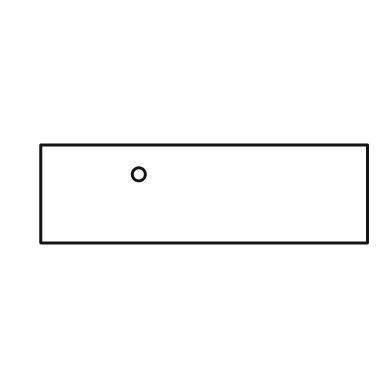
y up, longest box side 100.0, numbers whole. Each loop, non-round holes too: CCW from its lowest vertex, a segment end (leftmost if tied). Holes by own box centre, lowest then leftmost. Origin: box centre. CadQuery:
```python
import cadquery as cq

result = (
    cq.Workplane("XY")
    .moveTo(-50.0, -15.0)
    .lineTo(50.0, -15.0)
    .lineTo(50.0, 15.0)
    .lineTo(-50.0, 15.0)
    .close()
    .moveTo(-20.0, 6.0)
    .circle(2.0)
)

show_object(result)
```